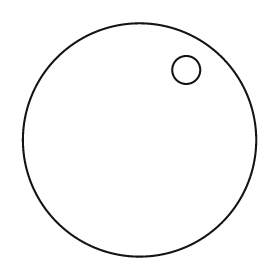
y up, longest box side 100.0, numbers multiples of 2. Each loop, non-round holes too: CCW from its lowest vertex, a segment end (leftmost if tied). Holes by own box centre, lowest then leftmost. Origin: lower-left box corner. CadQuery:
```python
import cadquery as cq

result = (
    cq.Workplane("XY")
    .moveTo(50.0, 50.0)
    .circle(50.0)
    .moveTo(70.0, 80.0)
    .circle(6.0)
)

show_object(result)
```